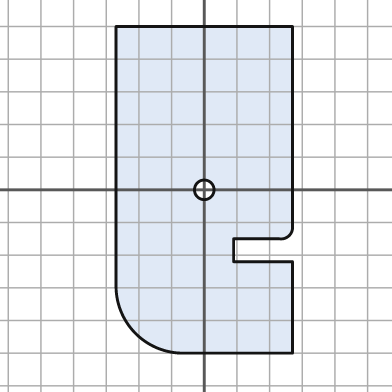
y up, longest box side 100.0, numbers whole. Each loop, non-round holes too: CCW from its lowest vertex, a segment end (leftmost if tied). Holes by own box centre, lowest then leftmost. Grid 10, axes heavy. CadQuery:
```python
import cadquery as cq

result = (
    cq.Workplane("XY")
    .moveTo(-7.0, -50.0)
    .lineTo(27.0, -50.0)
    .lineTo(27.0, -22.0)
    .lineTo(9.0, -22.0)
    .lineTo(9.0, -15.0)
    .lineTo(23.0, -15.0)
    .threePointArc((26.0, -14.0), (27.0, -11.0))
    .lineTo(27.0, 50.0)
    .lineTo(-27.0, 50.0)
    .lineTo(-27.0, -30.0)
    .threePointArc((-21.0, -44.0), (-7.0, -50.0))
    .close()
    .moveTo(0.0, 0.0)
    .circle(3.0)
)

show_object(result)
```